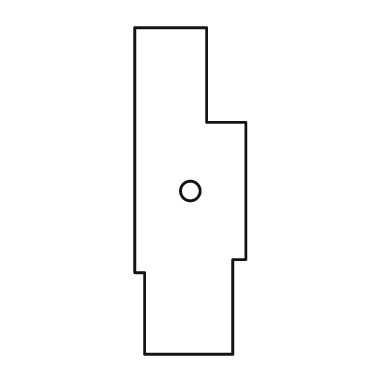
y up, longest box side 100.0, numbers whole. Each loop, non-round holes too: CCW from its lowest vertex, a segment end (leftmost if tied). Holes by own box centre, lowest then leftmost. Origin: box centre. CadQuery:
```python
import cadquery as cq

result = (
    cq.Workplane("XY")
    .moveTo(-14.0, -50.0)
    .lineTo(13.0, -50.0)
    .lineTo(13.0, -21.0)
    .lineTo(17.0, -21.0)
    .lineTo(17.0, 21.0)
    .lineTo(5.0, 21.0)
    .lineTo(5.0, 50.0)
    .lineTo(-17.0, 50.0)
    .lineTo(-17.0, -25.0)
    .lineTo(-14.0, -25.0)
    .close()
    .moveTo(0.0, 0.0)
    .circle(3.0)
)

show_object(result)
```